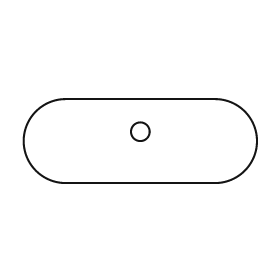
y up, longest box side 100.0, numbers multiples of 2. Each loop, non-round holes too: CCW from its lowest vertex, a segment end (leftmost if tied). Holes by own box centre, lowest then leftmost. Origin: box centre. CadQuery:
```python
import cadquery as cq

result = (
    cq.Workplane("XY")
    .moveTo(-32.0, -18.0)
    .lineTo(32.0, -18.0)
    .threePointArc((50.0, 0.0), (32.0, 18.0))
    .lineTo(-32.0, 18.0)
    .threePointArc((-50.0, 0.0), (-32.0, -18.0))
    .close()
    .moveTo(0.0, 4.0)
    .circle(4.0)
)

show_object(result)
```